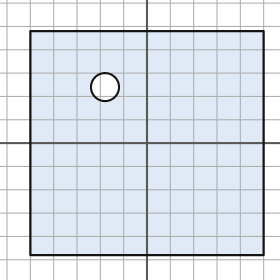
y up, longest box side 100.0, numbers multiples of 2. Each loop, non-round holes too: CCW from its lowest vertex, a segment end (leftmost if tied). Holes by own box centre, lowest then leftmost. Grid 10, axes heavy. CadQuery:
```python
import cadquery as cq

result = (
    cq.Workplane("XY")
    .moveTo(-50.0, -48.0)
    .lineTo(50.0, -48.0)
    .lineTo(50.0, 48.0)
    .lineTo(-50.0, 48.0)
    .close()
    .moveTo(-18.0, 24.0)
    .circle(6.0)
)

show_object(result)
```